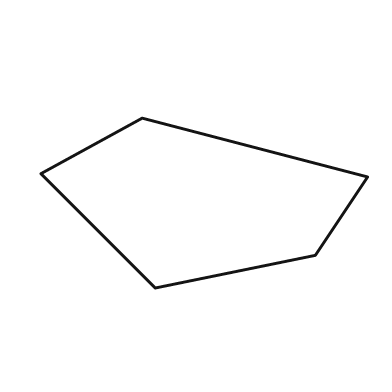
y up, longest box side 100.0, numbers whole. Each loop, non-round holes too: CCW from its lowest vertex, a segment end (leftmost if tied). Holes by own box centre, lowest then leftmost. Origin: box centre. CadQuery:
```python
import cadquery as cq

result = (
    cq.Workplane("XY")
    .moveTo(-15.0, -26.0)
    .lineTo(34.0, -16.0)
    .lineTo(50.0, 8.0)
    .lineTo(-19.0, 26.0)
    .lineTo(-50.0, 9.0)
    .close()
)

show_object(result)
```